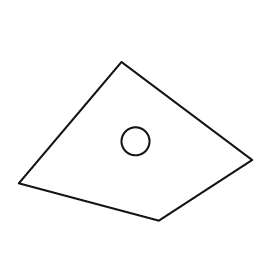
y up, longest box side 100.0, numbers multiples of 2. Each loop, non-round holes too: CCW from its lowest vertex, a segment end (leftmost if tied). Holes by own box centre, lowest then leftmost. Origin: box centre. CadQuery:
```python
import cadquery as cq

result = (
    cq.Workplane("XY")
    .moveTo(10.0, -34.0)
    .lineTo(50.0, -8.0)
    .lineTo(-6.0, 34.0)
    .lineTo(-50.0, -18.0)
    .close()
    .moveTo(0.0, 0.0)
    .circle(6.0)
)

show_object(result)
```